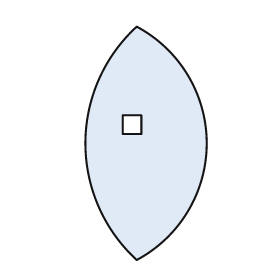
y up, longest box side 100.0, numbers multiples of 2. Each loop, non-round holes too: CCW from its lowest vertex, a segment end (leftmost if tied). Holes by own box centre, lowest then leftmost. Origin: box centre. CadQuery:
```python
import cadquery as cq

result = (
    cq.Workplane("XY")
    .moveTo(-4.0, -50.0)
    .threePointArc((26.0, 0.0), (-4.0, 50.0))
    .threePointArc((-26.0, 0.0), (-4.0, -50.0))
    .close()
    .moveTo(-10.0, 4.0)
    .lineTo(-2.0, 4.0)
    .lineTo(-2.0, 12.0)
    .lineTo(-10.0, 12.0)
    .close()
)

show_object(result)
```